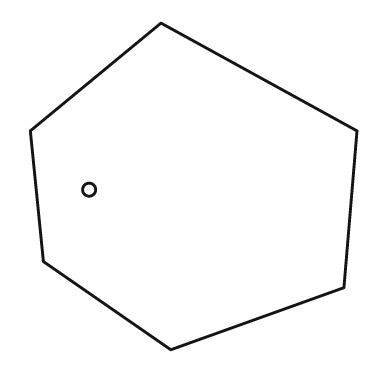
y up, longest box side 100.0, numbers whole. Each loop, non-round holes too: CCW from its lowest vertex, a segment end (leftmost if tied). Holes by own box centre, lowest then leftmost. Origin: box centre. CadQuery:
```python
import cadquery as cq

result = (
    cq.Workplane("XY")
    .moveTo(-7.0, -50.0)
    .lineTo(46.0, -31.0)
    .lineTo(50.0, 17.0)
    .lineTo(-10.0, 50.0)
    .lineTo(-50.0, 17.0)
    .lineTo(-46.0, -23.0)
    .close()
    .moveTo(-32.0, -1.0)
    .circle(2.0)
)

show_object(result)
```